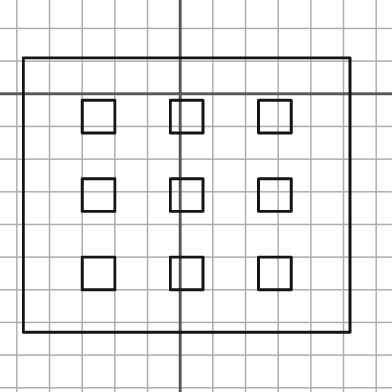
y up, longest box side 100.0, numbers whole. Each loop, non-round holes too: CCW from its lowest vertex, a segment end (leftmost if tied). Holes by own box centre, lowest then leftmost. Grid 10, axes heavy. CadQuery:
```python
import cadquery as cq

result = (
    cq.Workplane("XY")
    .moveTo(-48.0, -73.0)
    .lineTo(52.0, -73.0)
    .lineTo(52.0, 11.0)
    .lineTo(-48.0, 11.0)
    .close()
    .moveTo(-30.0, -60.0)
    .lineTo(-20.0, -60.0)
    .lineTo(-20.0, -50.0)
    .lineTo(-30.0, -50.0)
    .close()
    .moveTo(-3.0, -60.0)
    .lineTo(7.0, -60.0)
    .lineTo(7.0, -50.0)
    .lineTo(-3.0, -50.0)
    .close()
    .moveTo(24.0, -60.0)
    .lineTo(34.0, -60.0)
    .lineTo(34.0, -50.0)
    .lineTo(24.0, -50.0)
    .close()
    .moveTo(-30.0, -36.0)
    .lineTo(-20.0, -36.0)
    .lineTo(-20.0, -26.0)
    .lineTo(-30.0, -26.0)
    .close()
    .moveTo(-3.0, -36.0)
    .lineTo(7.0, -36.0)
    .lineTo(7.0, -26.0)
    .lineTo(-3.0, -26.0)
    .close()
    .moveTo(24.0, -36.0)
    .lineTo(34.0, -36.0)
    .lineTo(34.0, -26.0)
    .lineTo(24.0, -26.0)
    .close()
    .moveTo(-30.0, -12.0)
    .lineTo(-20.0, -12.0)
    .lineTo(-20.0, -2.0)
    .lineTo(-30.0, -2.0)
    .close()
    .moveTo(-3.0, -12.0)
    .lineTo(7.0, -12.0)
    .lineTo(7.0, -2.0)
    .lineTo(-3.0, -2.0)
    .close()
    .moveTo(24.0, -12.0)
    .lineTo(34.0, -12.0)
    .lineTo(34.0, -2.0)
    .lineTo(24.0, -2.0)
    .close()
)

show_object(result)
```